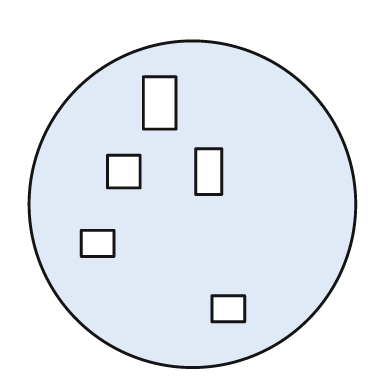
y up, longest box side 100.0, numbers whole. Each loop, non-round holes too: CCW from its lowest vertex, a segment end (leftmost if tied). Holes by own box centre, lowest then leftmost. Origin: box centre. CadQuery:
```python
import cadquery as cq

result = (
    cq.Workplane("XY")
    .moveTo(0.0, 0.0)
    .circle(50.0)
    .moveTo(6.0, -36.0)
    .lineTo(16.0, -36.0)
    .lineTo(16.0, -28.0)
    .lineTo(6.0, -28.0)
    .close()
    .moveTo(-34.0, -16.0)
    .lineTo(-24.0, -16.0)
    .lineTo(-24.0, -8.0)
    .lineTo(-34.0, -8.0)
    .close()
    .moveTo(-26.0, 5.0)
    .lineTo(-16.0, 5.0)
    .lineTo(-16.0, 15.0)
    .lineTo(-26.0, 15.0)
    .close()
    .moveTo(1.0, 3.0)
    .lineTo(9.0, 3.0)
    .lineTo(9.0, 17.0)
    .lineTo(1.0, 17.0)
    .close()
    .moveTo(-15.0, 23.0)
    .lineTo(-5.0, 23.0)
    .lineTo(-5.0, 39.0)
    .lineTo(-15.0, 39.0)
    .close()
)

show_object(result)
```